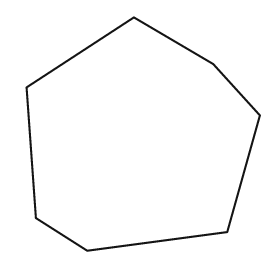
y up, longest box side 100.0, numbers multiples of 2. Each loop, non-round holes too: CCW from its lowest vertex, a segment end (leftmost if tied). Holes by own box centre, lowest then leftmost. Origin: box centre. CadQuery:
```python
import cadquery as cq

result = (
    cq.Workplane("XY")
    .moveTo(-24.0, -50.0)
    .lineTo(36.0, -42.0)
    .lineTo(50.0, 8.0)
    .lineTo(30.0, 30.0)
    .lineTo(-4.0, 50.0)
    .lineTo(-50.0, 20.0)
    .lineTo(-46.0, -36.0)
    .close()
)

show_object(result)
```